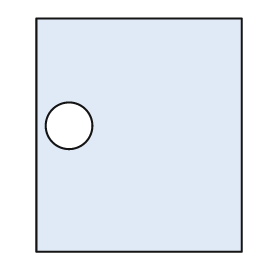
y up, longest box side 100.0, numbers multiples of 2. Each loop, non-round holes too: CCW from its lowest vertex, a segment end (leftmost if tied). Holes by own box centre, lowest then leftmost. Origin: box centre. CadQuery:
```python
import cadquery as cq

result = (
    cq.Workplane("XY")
    .moveTo(-44.0, -50.0)
    .lineTo(44.0, -50.0)
    .lineTo(44.0, 50.0)
    .lineTo(-44.0, 50.0)
    .close()
    .moveTo(-30.0, 4.0)
    .circle(10.0)
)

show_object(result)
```